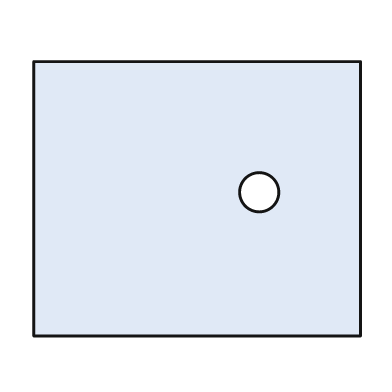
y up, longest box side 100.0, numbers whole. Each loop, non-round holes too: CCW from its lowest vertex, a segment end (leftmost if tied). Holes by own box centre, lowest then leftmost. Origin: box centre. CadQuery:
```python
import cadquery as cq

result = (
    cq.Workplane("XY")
    .moveTo(-50.0, -42.0)
    .lineTo(50.0, -42.0)
    .lineTo(50.0, 42.0)
    .lineTo(-50.0, 42.0)
    .close()
    .moveTo(19.0, 2.0)
    .circle(6.0)
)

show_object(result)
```